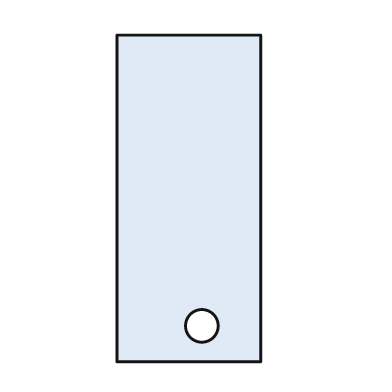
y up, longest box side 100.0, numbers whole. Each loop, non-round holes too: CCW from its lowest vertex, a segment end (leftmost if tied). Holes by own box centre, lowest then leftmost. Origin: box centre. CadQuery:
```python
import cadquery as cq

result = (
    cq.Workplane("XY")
    .moveTo(-22.0, -50.0)
    .lineTo(22.0, -50.0)
    .lineTo(22.0, 50.0)
    .lineTo(-22.0, 50.0)
    .close()
    .moveTo(4.0, -39.0)
    .circle(5.0)
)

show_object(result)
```